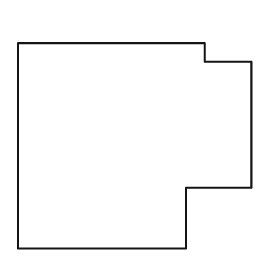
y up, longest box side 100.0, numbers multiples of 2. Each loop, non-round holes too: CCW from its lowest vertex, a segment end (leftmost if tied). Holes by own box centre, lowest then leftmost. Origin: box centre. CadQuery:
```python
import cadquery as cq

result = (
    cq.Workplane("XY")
    .moveTo(-50.0, -44.0)
    .lineTo(22.0, -44.0)
    .lineTo(22.0, -18.0)
    .lineTo(50.0, -18.0)
    .lineTo(50.0, 36.0)
    .lineTo(30.0, 36.0)
    .lineTo(30.0, 44.0)
    .lineTo(-50.0, 44.0)
    .close()
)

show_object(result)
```